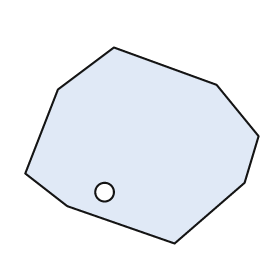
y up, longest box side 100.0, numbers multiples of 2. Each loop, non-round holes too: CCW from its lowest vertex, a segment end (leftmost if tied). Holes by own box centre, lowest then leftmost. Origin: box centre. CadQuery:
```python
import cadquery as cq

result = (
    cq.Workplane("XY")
    .moveTo(14.0, -42.0)
    .lineTo(44.0, -16.0)
    .lineTo(50.0, 4.0)
    .lineTo(32.0, 26.0)
    .lineTo(-12.0, 42.0)
    .lineTo(-36.0, 24.0)
    .lineTo(-50.0, -12.0)
    .lineTo(-32.0, -26.0)
    .close()
    .moveTo(-16.0, -20.0)
    .circle(4.0)
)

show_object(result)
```